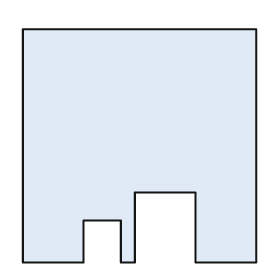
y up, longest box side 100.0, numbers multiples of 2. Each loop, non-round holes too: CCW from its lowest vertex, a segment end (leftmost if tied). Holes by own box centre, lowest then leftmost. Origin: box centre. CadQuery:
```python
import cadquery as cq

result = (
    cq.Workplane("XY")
    .moveTo(-50.0, -50.0)
    .lineTo(-24.0, -50.0)
    .lineTo(-24.0, -32.0)
    .lineTo(-8.0, -32.0)
    .lineTo(-8.0, -50.0)
    .lineTo(-2.0, -50.0)
    .lineTo(-2.0, -20.0)
    .lineTo(24.0, -20.0)
    .lineTo(24.0, -50.0)
    .lineTo(50.0, -50.0)
    .lineTo(50.0, 50.0)
    .lineTo(-50.0, 50.0)
    .close()
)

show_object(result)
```